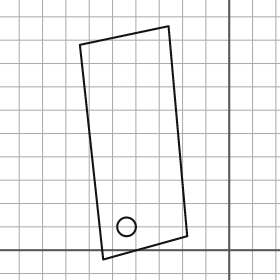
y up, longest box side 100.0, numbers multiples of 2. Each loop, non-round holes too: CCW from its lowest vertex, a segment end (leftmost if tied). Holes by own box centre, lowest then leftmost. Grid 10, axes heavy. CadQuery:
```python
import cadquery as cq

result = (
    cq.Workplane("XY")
    .moveTo(-54.0, -4.0)
    .lineTo(-18.0, 6.0)
    .lineTo(-26.0, 96.0)
    .lineTo(-64.0, 88.0)
    .close()
    .moveTo(-44.0, 10.0)
    .circle(4.0)
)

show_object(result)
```